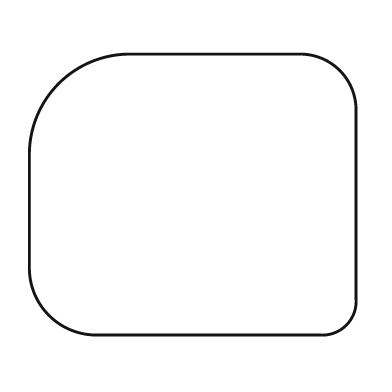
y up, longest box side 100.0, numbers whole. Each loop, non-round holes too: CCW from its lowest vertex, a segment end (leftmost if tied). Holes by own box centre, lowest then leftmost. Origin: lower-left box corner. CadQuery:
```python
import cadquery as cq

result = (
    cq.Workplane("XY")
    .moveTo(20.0, 0.0)
    .lineTo(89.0, 0.0)
    .threePointArc((97.0, 3.0), (100.0, 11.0))
    .lineTo(100.0, 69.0)
    .threePointArc((95.0, 81.0), (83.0, 86.0))
    .lineTo(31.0, 86.0)
    .threePointArc((9.0, 77.0), (0.0, 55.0))
    .lineTo(0.0, 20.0)
    .threePointArc((6.0, 6.0), (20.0, 0.0))
    .close()
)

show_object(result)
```